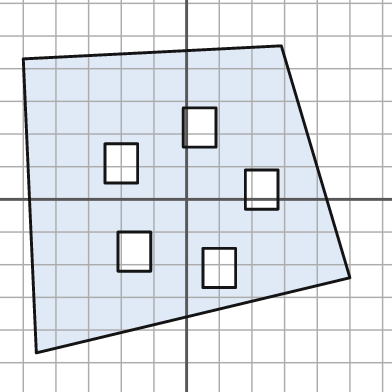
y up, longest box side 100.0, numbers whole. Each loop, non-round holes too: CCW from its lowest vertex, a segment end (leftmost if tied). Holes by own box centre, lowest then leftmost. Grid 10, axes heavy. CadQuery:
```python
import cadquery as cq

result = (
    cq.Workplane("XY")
    .moveTo(-46.0, -47.0)
    .lineTo(50.0, -24.0)
    .lineTo(29.0, 47.0)
    .lineTo(-50.0, 43.0)
    .close()
    .moveTo(5.0, -27.0)
    .lineTo(15.0, -27.0)
    .lineTo(15.0, -15.0)
    .lineTo(5.0, -15.0)
    .close()
    .moveTo(-21.0, -22.0)
    .lineTo(-11.0, -22.0)
    .lineTo(-11.0, -10.0)
    .lineTo(-21.0, -10.0)
    .close()
    .moveTo(18.0, -3.0)
    .lineTo(28.0, -3.0)
    .lineTo(28.0, 9.0)
    .lineTo(18.0, 9.0)
    .close()
    .moveTo(-25.0, 5.0)
    .lineTo(-15.0, 5.0)
    .lineTo(-15.0, 17.0)
    .lineTo(-25.0, 17.0)
    .close()
    .moveTo(-1.0, 16.0)
    .lineTo(9.0, 16.0)
    .lineTo(9.0, 28.0)
    .lineTo(-1.0, 28.0)
    .close()
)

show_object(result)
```